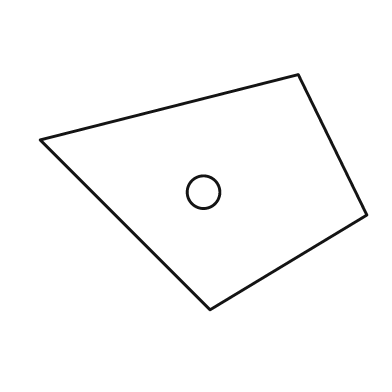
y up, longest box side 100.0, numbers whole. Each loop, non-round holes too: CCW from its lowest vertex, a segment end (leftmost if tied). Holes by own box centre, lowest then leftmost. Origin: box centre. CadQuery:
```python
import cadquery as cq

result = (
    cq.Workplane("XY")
    .moveTo(2.0, -36.0)
    .lineTo(50.0, -7.0)
    .lineTo(29.0, 36.0)
    .lineTo(-50.0, 16.0)
    .close()
    .moveTo(0.0, 0.0)
    .circle(5.0)
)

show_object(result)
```